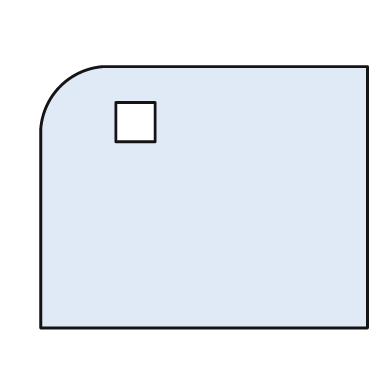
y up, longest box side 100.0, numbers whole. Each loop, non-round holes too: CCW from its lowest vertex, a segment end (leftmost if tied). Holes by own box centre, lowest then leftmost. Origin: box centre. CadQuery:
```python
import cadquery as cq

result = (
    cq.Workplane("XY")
    .moveTo(-50.0, -40.0)
    .lineTo(50.0, -40.0)
    .lineTo(50.0, 40.0)
    .lineTo(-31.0, 40.0)
    .threePointArc((-44.0, 34.0), (-50.0, 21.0))
    .close()
    .moveTo(-27.0, 17.0)
    .lineTo(-15.0, 17.0)
    .lineTo(-15.0, 29.0)
    .lineTo(-27.0, 29.0)
    .close()
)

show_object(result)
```